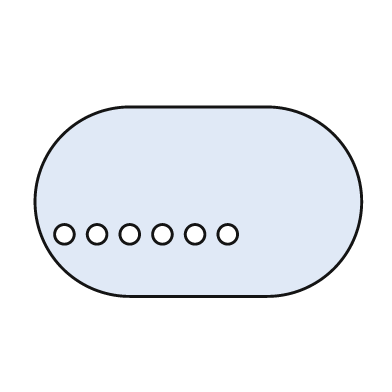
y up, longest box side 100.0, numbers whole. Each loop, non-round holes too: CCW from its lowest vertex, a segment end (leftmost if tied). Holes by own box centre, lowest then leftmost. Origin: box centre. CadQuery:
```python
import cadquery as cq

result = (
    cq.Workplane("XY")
    .moveTo(-21.0, -29.0)
    .lineTo(21.0, -29.0)
    .threePointArc((50.0, 0.0), (21.0, 29.0))
    .lineTo(-21.0, 29.0)
    .threePointArc((-50.0, 0.0), (-21.0, -29.0))
    .close()
    .moveTo(-41.0, -10.0)
    .circle(3.0)
    .moveTo(-31.0, -10.0)
    .circle(3.0)
    .moveTo(-21.0, -10.0)
    .circle(3.0)
    .moveTo(-11.0, -10.0)
    .circle(3.0)
    .moveTo(-1.0, -10.0)
    .circle(3.0)
    .moveTo(9.0, -10.0)
    .circle(3.0)
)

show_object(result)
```